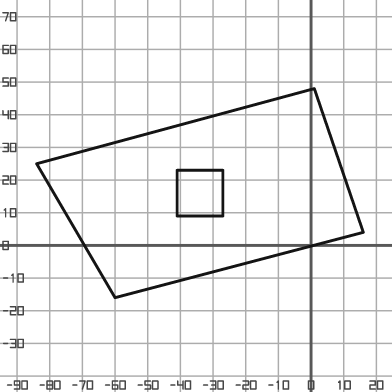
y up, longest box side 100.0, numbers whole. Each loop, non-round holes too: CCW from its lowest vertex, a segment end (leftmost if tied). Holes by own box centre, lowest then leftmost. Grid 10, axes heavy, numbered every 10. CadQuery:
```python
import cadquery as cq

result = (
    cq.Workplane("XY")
    .moveTo(-60.0, -16.0)
    .lineTo(16.0, 4.0)
    .lineTo(1.0, 48.0)
    .lineTo(-84.0, 25.0)
    .close()
    .moveTo(-41.0, 9.0)
    .lineTo(-27.0, 9.0)
    .lineTo(-27.0, 23.0)
    .lineTo(-41.0, 23.0)
    .close()
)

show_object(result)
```